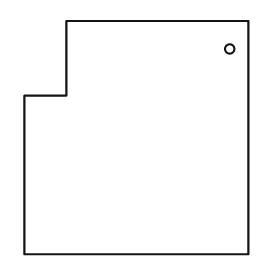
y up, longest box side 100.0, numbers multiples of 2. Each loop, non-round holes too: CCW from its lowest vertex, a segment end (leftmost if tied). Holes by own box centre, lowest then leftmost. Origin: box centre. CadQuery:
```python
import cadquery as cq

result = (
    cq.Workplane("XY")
    .moveTo(-48.0, -50.0)
    .lineTo(48.0, -50.0)
    .lineTo(48.0, 50.0)
    .lineTo(-30.0, 50.0)
    .lineTo(-30.0, 18.0)
    .lineTo(-48.0, 18.0)
    .close()
    .moveTo(40.0, 38.0)
    .circle(2.0)
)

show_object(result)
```